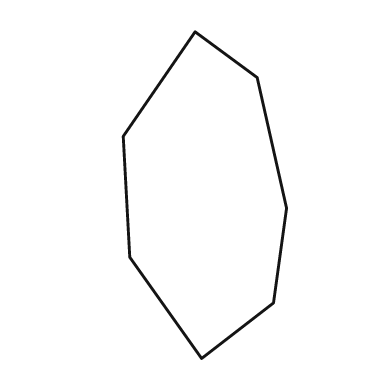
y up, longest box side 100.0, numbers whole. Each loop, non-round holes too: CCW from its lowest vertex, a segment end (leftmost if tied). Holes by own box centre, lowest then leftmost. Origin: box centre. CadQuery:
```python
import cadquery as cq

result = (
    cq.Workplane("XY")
    .moveTo(-1.0, -50.0)
    .lineTo(21.0, -33.0)
    .lineTo(25.0, -4.0)
    .lineTo(16.0, 36.0)
    .lineTo(-3.0, 50.0)
    .lineTo(-25.0, 18.0)
    .lineTo(-23.0, -19.0)
    .close()
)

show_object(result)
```